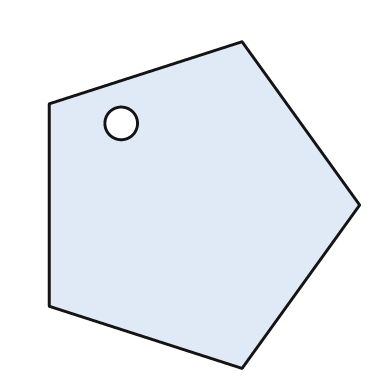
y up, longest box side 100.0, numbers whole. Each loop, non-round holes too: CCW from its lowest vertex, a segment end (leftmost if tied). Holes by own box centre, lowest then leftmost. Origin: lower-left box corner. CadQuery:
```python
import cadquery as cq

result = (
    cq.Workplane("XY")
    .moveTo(59.0, 0.0)
    .lineTo(95.0, 50.0)
    .lineTo(59.0, 100.0)
    .lineTo(0.0, 81.0)
    .lineTo(0.0, 19.0)
    .close()
    .moveTo(22.0, 75.0)
    .circle(5.0)
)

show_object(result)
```